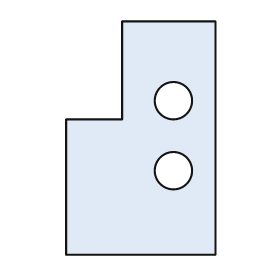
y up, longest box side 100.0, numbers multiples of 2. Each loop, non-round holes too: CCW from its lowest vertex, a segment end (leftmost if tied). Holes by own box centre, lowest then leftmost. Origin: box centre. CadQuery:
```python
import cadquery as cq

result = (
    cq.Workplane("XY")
    .moveTo(-32.0, -50.0)
    .lineTo(32.0, -50.0)
    .lineTo(32.0, 50.0)
    .lineTo(-8.0, 50.0)
    .lineTo(-8.0, 8.0)
    .lineTo(-32.0, 8.0)
    .close()
    .moveTo(14.0, -14.0)
    .circle(8.0)
    .moveTo(14.0, 16.0)
    .circle(8.0)
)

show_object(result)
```